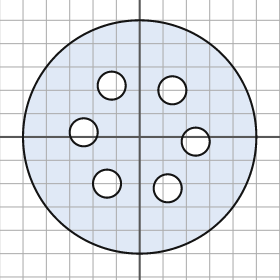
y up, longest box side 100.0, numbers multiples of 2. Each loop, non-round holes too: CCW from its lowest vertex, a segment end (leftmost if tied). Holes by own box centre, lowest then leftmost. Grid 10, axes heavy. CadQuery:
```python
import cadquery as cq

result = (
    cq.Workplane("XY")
    .moveTo(0.0, 0.0)
    .circle(50.0)
    .moveTo(12.0, -22.0)
    .circle(6.0)
    .moveTo(-14.0, -20.0)
    .circle(6.0)
    .moveTo(24.0, -2.0)
    .circle(6.0)
    .moveTo(-24.0, 2.0)
    .circle(6.0)
    .moveTo(14.0, 20.0)
    .circle(6.0)
    .moveTo(-12.0, 22.0)
    .circle(6.0)
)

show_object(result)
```